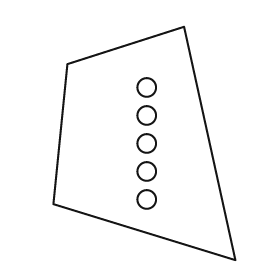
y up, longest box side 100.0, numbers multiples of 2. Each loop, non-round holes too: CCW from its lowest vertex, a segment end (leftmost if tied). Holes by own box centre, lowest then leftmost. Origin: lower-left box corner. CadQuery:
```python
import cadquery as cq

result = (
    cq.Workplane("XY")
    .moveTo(78.0, 0.0)
    .lineTo(56.0, 100.0)
    .lineTo(6.0, 84.0)
    .lineTo(0.0, 24.0)
    .close()
    .moveTo(40.0, 26.0)
    .circle(4.0)
    .moveTo(40.0, 38.0)
    .circle(4.0)
    .moveTo(40.0, 50.0)
    .circle(4.0)
    .moveTo(40.0, 62.0)
    .circle(4.0)
    .moveTo(40.0, 74.0)
    .circle(4.0)
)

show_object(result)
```